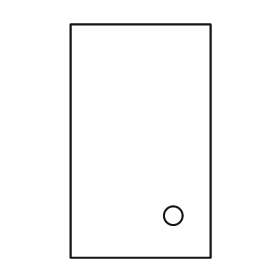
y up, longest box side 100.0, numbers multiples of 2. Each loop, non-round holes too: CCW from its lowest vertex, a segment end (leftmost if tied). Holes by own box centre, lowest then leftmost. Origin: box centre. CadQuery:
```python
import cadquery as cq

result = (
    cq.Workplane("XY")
    .moveTo(-30.0, -50.0)
    .lineTo(30.0, -50.0)
    .lineTo(30.0, 50.0)
    .lineTo(-30.0, 50.0)
    .close()
    .moveTo(14.0, -32.0)
    .circle(4.0)
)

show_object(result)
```